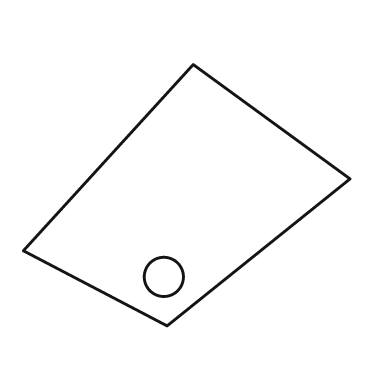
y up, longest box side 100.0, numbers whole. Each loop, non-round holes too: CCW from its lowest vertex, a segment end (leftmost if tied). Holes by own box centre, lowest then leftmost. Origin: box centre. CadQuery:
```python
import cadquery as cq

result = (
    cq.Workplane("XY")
    .moveTo(-6.0, -40.0)
    .lineTo(50.0, 5.0)
    .lineTo(2.0, 40.0)
    .lineTo(-50.0, -17.0)
    .close()
    .moveTo(-7.0, -25.0)
    .circle(6.0)
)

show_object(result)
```